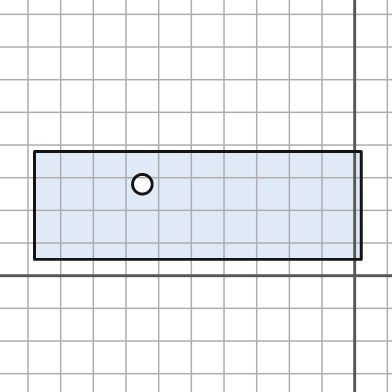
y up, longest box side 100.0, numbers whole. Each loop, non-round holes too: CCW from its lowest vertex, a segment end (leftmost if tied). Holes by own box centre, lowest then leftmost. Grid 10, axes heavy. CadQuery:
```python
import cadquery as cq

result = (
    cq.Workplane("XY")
    .moveTo(-98.0, 5.0)
    .lineTo(2.0, 5.0)
    .lineTo(2.0, 38.0)
    .lineTo(-98.0, 38.0)
    .close()
    .moveTo(-65.0, 28.0)
    .circle(3.0)
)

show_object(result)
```